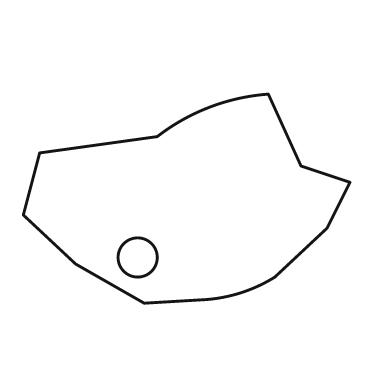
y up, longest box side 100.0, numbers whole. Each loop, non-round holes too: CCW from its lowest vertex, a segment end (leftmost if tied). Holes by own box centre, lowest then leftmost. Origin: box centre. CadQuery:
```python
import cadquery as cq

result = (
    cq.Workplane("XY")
    .moveTo(-13.0, -32.0)
    .lineTo(4.0, -31.0)
    .threePointArc((16.0, -29.0), (27.0, -24.0))
    .lineTo(43.0, -9.0)
    .lineTo(50.0, 5.0)
    .lineTo(35.0, 10.0)
    .lineTo(25.0, 32.0)
    .threePointArc((7.0, 28.0), (-9.0, 19.0))
    .lineTo(-45.0, 14.0)
    .lineTo(-50.0, -5.0)
    .lineTo(-34.0, -20.0)
    .close()
    .moveTo(-15.0, -18.0)
    .circle(6.0)
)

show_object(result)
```